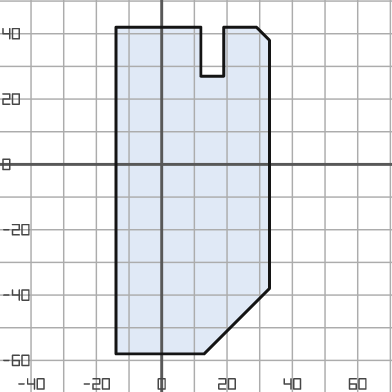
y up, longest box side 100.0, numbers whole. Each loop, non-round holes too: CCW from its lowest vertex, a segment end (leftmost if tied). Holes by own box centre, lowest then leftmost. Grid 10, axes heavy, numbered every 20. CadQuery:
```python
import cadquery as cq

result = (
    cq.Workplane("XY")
    .moveTo(-14.0, -58.0)
    .lineTo(13.0, -58.0)
    .lineTo(33.0, -38.0)
    .lineTo(33.0, 38.0)
    .lineTo(29.0, 42.0)
    .lineTo(19.0, 42.0)
    .lineTo(19.0, 27.0)
    .lineTo(12.0, 27.0)
    .lineTo(12.0, 42.0)
    .lineTo(-14.0, 42.0)
    .close()
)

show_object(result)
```